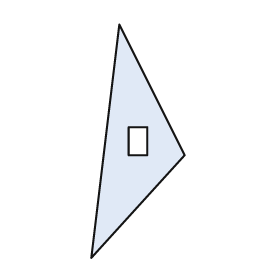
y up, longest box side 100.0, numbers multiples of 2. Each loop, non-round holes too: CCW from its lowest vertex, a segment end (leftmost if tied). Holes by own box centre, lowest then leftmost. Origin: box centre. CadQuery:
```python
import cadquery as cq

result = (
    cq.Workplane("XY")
    .moveTo(-20.0, -50.0)
    .lineTo(20.0, -6.0)
    .lineTo(-8.0, 50.0)
    .close()
    .moveTo(-4.0, -6.0)
    .lineTo(4.0, -6.0)
    .lineTo(4.0, 6.0)
    .lineTo(-4.0, 6.0)
    .close()
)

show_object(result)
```